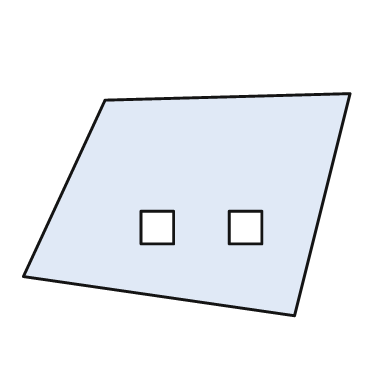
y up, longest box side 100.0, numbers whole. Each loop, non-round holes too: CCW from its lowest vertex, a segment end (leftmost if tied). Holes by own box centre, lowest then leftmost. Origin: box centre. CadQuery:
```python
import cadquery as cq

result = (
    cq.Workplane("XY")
    .moveTo(33.0, -34.0)
    .lineTo(50.0, 34.0)
    .lineTo(-25.0, 32.0)
    .lineTo(-50.0, -22.0)
    .close()
    .moveTo(-14.0, -12.0)
    .lineTo(-4.0, -12.0)
    .lineTo(-4.0, -2.0)
    .lineTo(-14.0, -2.0)
    .close()
    .moveTo(13.0, -12.0)
    .lineTo(23.0, -12.0)
    .lineTo(23.0, -2.0)
    .lineTo(13.0, -2.0)
    .close()
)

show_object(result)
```